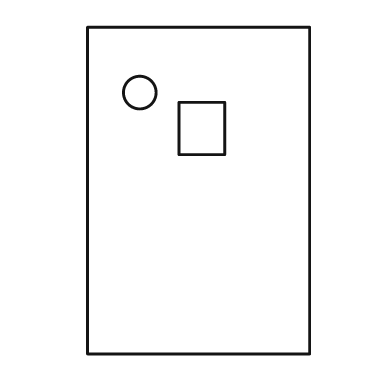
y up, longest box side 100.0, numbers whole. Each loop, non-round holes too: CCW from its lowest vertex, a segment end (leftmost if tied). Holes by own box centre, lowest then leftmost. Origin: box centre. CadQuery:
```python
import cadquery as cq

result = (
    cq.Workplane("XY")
    .moveTo(-34.0, -50.0)
    .lineTo(34.0, -50.0)
    .lineTo(34.0, 50.0)
    .lineTo(-34.0, 50.0)
    .close()
    .moveTo(-6.0, 11.0)
    .lineTo(8.0, 11.0)
    .lineTo(8.0, 27.0)
    .lineTo(-6.0, 27.0)
    .close()
    .moveTo(-18.0, 30.0)
    .circle(5.0)
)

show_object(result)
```